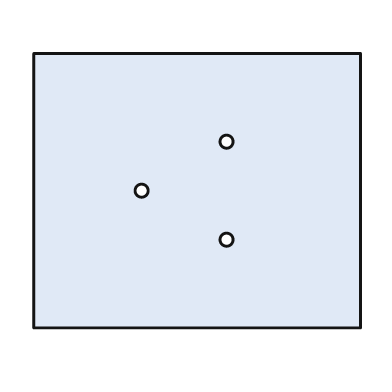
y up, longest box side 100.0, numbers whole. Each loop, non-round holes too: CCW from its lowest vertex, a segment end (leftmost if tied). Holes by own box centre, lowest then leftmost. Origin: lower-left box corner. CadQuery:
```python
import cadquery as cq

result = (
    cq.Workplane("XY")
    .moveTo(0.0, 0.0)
    .lineTo(100.0, 0.0)
    .lineTo(100.0, 84.0)
    .lineTo(0.0, 84.0)
    .close()
    .moveTo(59.0, 27.0)
    .circle(2.0)
    .moveTo(33.0, 42.0)
    .circle(2.0)
    .moveTo(59.0, 57.0)
    .circle(2.0)
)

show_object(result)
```